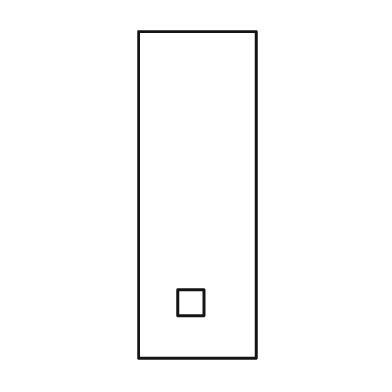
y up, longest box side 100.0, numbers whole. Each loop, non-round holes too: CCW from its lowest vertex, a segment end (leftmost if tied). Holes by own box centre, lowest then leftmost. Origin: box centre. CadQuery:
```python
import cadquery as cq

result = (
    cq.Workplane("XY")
    .moveTo(-18.0, -50.0)
    .lineTo(18.0, -50.0)
    .lineTo(18.0, 50.0)
    .lineTo(-18.0, 50.0)
    .close()
    .moveTo(-6.0, -37.0)
    .lineTo(2.0, -37.0)
    .lineTo(2.0, -29.0)
    .lineTo(-6.0, -29.0)
    .close()
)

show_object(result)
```